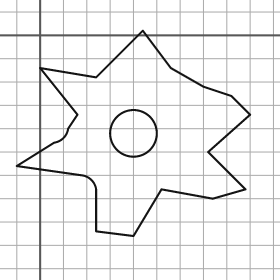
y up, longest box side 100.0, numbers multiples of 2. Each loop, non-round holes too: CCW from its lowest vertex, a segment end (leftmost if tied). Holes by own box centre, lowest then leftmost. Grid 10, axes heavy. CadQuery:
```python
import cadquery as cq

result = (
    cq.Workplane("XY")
    .moveTo(40.0, -86.0)
    .lineTo(52.0, -66.0)
    .lineTo(74.0, -70.0)
    .lineTo(88.0, -66.0)
    .lineTo(72.0, -50.0)
    .lineTo(90.0, -34.0)
    .lineTo(82.0, -26.0)
    .lineTo(70.0, -22.0)
    .lineTo(56.0, -14.0)
    .lineTo(44.0, 2.0)
    .lineTo(24.0, -18.0)
    .lineTo(0.0, -14.0)
    .lineTo(16.0, -34.0)
    .lineTo(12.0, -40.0)
    .threePointArc((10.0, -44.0), (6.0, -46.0))
    .lineTo(-10.0, -56.0)
    .lineTo(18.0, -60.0)
    .threePointArc((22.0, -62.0), (24.0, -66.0))
    .lineTo(24.0, -84.0)
    .close()
    .moveTo(40.0, -42.0)
    .circle(10.0)
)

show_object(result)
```